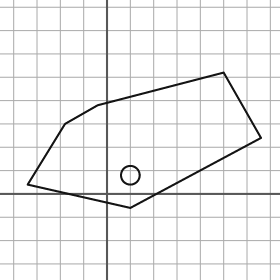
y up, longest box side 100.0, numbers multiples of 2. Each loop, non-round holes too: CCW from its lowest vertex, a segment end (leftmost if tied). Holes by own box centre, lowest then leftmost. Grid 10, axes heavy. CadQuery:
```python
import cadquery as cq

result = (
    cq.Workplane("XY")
    .moveTo(10.0, -6.0)
    .lineTo(66.0, 24.0)
    .lineTo(50.0, 52.0)
    .lineTo(-4.0, 38.0)
    .lineTo(-18.0, 30.0)
    .lineTo(-34.0, 4.0)
    .close()
    .moveTo(10.0, 8.0)
    .circle(4.0)
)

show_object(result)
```